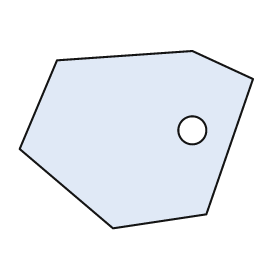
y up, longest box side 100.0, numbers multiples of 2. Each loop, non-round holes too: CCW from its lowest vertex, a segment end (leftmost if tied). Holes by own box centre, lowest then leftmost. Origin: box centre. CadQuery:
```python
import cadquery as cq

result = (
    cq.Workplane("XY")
    .moveTo(-10.0, -38.0)
    .lineTo(30.0, -32.0)
    .lineTo(50.0, 26.0)
    .lineTo(24.0, 38.0)
    .lineTo(-34.0, 34.0)
    .lineTo(-50.0, -4.0)
    .close()
    .moveTo(24.0, 4.0)
    .circle(6.0)
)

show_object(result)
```